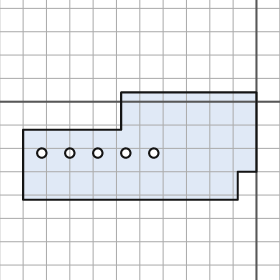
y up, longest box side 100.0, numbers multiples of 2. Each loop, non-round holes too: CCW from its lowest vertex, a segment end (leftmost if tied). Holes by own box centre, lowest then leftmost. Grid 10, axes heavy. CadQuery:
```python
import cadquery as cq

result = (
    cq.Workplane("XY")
    .moveTo(-100.0, -42.0)
    .lineTo(-8.0, -42.0)
    .lineTo(-8.0, -30.0)
    .lineTo(0.0, -30.0)
    .lineTo(0.0, 4.0)
    .lineTo(-58.0, 4.0)
    .lineTo(-58.0, -12.0)
    .lineTo(-100.0, -12.0)
    .close()
    .moveTo(-92.0, -22.0)
    .circle(2.0)
    .moveTo(-80.0, -22.0)
    .circle(2.0)
    .moveTo(-68.0, -22.0)
    .circle(2.0)
    .moveTo(-56.0, -22.0)
    .circle(2.0)
    .moveTo(-44.0, -22.0)
    .circle(2.0)
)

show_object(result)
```